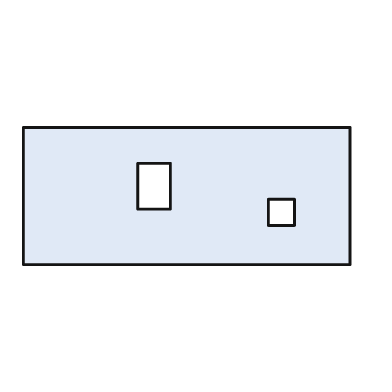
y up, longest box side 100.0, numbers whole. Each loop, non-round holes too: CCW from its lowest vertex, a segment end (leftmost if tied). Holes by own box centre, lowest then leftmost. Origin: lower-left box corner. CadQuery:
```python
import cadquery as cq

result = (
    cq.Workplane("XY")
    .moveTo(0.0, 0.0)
    .lineTo(100.0, 0.0)
    .lineTo(100.0, 42.0)
    .lineTo(0.0, 42.0)
    .close()
    .moveTo(75.0, 12.0)
    .lineTo(83.0, 12.0)
    .lineTo(83.0, 20.0)
    .lineTo(75.0, 20.0)
    .close()
    .moveTo(35.0, 17.0)
    .lineTo(45.0, 17.0)
    .lineTo(45.0, 31.0)
    .lineTo(35.0, 31.0)
    .close()
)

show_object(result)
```